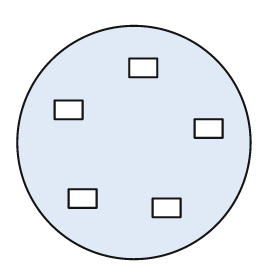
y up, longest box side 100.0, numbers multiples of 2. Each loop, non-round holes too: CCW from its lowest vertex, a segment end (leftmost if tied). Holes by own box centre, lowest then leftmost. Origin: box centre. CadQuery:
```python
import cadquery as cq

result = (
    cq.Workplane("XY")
    .moveTo(0.0, 0.0)
    .circle(50.0)
    .moveTo(8.0, -32.0)
    .lineTo(20.0, -32.0)
    .lineTo(20.0, -24.0)
    .lineTo(8.0, -24.0)
    .close()
    .moveTo(-28.0, -28.0)
    .lineTo(-16.0, -28.0)
    .lineTo(-16.0, -20.0)
    .lineTo(-28.0, -20.0)
    .close()
    .moveTo(26.0, 2.0)
    .lineTo(38.0, 2.0)
    .lineTo(38.0, 10.0)
    .lineTo(26.0, 10.0)
    .close()
    .moveTo(-34.0, 10.0)
    .lineTo(-22.0, 10.0)
    .lineTo(-22.0, 18.0)
    .lineTo(-34.0, 18.0)
    .close()
    .moveTo(-2.0, 28.0)
    .lineTo(10.0, 28.0)
    .lineTo(10.0, 36.0)
    .lineTo(-2.0, 36.0)
    .close()
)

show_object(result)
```